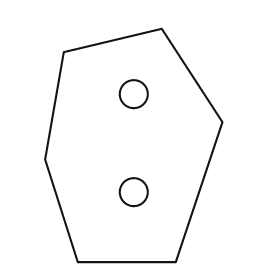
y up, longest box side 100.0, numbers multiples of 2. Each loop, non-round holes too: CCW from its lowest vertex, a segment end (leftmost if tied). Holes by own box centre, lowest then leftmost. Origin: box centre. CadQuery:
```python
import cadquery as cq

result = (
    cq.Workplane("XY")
    .moveTo(-24.0, -50.0)
    .lineTo(18.0, -50.0)
    .lineTo(38.0, 10.0)
    .lineTo(12.0, 50.0)
    .lineTo(-30.0, 40.0)
    .lineTo(-38.0, -6.0)
    .close()
    .moveTo(0.0, -20.0)
    .circle(6.0)
    .moveTo(0.0, 22.0)
    .circle(6.0)
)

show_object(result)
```